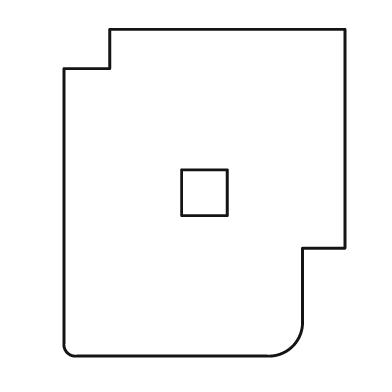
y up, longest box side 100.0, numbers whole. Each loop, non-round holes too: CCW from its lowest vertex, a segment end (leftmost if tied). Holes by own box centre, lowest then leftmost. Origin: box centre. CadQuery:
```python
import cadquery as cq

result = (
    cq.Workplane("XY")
    .moveTo(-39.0, -50.0)
    .lineTo(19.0, -50.0)
    .threePointArc((27.0, -47.0), (30.0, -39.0))
    .lineTo(30.0, -17.0)
    .lineTo(43.0, -17.0)
    .lineTo(43.0, 50.0)
    .lineTo(-29.0, 50.0)
    .lineTo(-29.0, 38.0)
    .lineTo(-43.0, 38.0)
    .lineTo(-43.0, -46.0)
    .threePointArc((-42.0, -49.0), (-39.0, -50.0))
    .close()
    .moveTo(-7.0, -7.0)
    .lineTo(7.0, -7.0)
    .lineTo(7.0, 7.0)
    .lineTo(-7.0, 7.0)
    .close()
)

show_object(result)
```